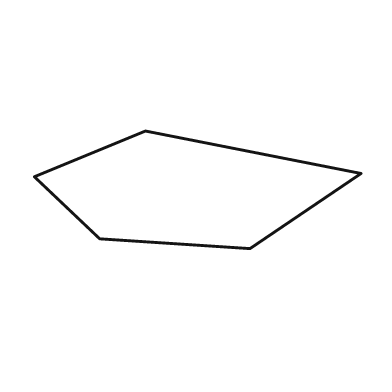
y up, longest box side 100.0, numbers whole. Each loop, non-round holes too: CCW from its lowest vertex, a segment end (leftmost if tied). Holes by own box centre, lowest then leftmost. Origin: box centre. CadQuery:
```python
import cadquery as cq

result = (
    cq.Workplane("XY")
    .moveTo(16.0, -18.0)
    .lineTo(50.0, 5.0)
    .lineTo(-16.0, 18.0)
    .lineTo(-50.0, 4.0)
    .lineTo(-30.0, -15.0)
    .close()
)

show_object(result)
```